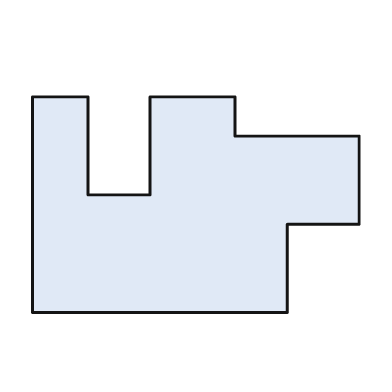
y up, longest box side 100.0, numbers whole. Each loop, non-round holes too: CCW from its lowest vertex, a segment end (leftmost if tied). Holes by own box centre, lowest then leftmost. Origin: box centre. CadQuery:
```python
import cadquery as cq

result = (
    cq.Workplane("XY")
    .moveTo(-50.0, -33.0)
    .lineTo(28.0, -33.0)
    .lineTo(28.0, -6.0)
    .lineTo(50.0, -6.0)
    .lineTo(50.0, 21.0)
    .lineTo(12.0, 21.0)
    .lineTo(12.0, 33.0)
    .lineTo(-14.0, 33.0)
    .lineTo(-14.0, 3.0)
    .lineTo(-33.0, 3.0)
    .lineTo(-33.0, 33.0)
    .lineTo(-50.0, 33.0)
    .close()
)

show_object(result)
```